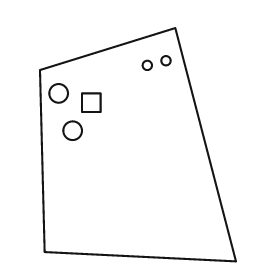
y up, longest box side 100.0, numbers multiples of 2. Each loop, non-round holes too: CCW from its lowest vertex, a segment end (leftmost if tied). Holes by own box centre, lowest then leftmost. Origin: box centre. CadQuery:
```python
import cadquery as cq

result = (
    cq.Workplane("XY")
    .moveTo(42.0, -50.0)
    .lineTo(16.0, 50.0)
    .lineTo(-42.0, 32.0)
    .lineTo(-40.0, -46.0)
    .close()
    .moveTo(-28.0, 6.0)
    .circle(4.0)
    .moveTo(-24.0, 14.0)
    .lineTo(-16.0, 14.0)
    .lineTo(-16.0, 22.0)
    .lineTo(-24.0, 22.0)
    .close()
    .moveTo(-34.0, 22.0)
    .circle(4.0)
    .moveTo(4.0, 34.0)
    .circle(2.0)
    .moveTo(12.0, 36.0)
    .circle(2.0)
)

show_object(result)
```